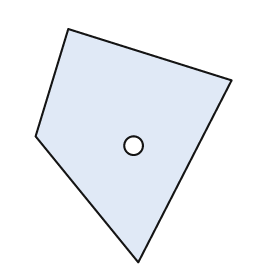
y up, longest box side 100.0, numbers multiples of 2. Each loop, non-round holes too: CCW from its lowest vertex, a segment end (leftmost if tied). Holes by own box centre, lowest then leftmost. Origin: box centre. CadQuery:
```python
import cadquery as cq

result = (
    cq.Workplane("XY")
    .moveTo(2.0, -50.0)
    .lineTo(42.0, 28.0)
    .lineTo(-28.0, 50.0)
    .lineTo(-42.0, 4.0)
    .close()
    .moveTo(0.0, 0.0)
    .circle(4.0)
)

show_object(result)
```